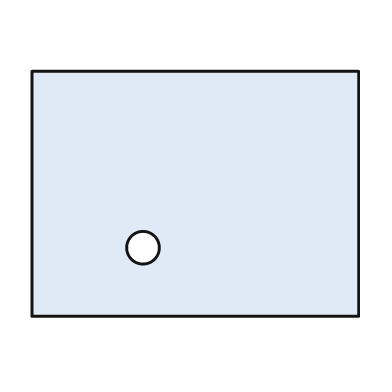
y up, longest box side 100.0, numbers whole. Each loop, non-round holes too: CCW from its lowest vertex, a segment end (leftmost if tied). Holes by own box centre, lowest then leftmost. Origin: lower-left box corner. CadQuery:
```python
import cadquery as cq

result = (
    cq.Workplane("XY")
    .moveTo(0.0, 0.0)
    .lineTo(100.0, 0.0)
    .lineTo(100.0, 75.0)
    .lineTo(0.0, 75.0)
    .close()
    .moveTo(34.0, 21.0)
    .circle(5.0)
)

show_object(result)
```